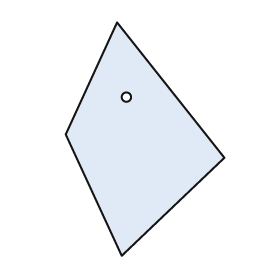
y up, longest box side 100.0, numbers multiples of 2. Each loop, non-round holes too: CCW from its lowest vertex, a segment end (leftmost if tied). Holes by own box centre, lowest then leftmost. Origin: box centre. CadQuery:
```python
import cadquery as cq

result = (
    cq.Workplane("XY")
    .moveTo(-10.0, -50.0)
    .lineTo(34.0, -8.0)
    .lineTo(-12.0, 50.0)
    .lineTo(-34.0, 2.0)
    .close()
    .moveTo(-8.0, 18.0)
    .circle(2.0)
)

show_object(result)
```